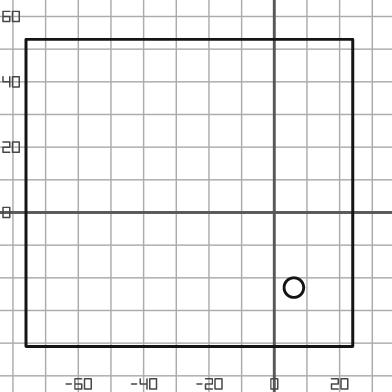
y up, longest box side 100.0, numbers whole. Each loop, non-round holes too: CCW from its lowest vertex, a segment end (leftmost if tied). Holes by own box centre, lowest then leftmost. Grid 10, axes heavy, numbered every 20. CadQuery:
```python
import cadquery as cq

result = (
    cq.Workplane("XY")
    .moveTo(-76.0, -41.0)
    .lineTo(24.0, -41.0)
    .lineTo(24.0, 53.0)
    .lineTo(-76.0, 53.0)
    .close()
    .moveTo(6.0, -23.0)
    .circle(3.0)
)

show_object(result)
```